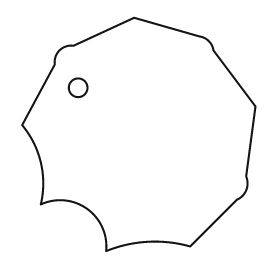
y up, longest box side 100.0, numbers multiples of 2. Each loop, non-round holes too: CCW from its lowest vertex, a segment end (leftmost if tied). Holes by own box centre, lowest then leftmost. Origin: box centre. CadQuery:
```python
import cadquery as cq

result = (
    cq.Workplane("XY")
    .moveTo(-14.0, -50.0)
    .threePointArc((4.0, -46.0), (22.0, -48.0))
    .lineTo(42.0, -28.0)
    .threePointArc((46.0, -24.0), (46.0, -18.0))
    .lineTo(50.0, 12.0)
    .lineTo(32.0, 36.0)
    .threePointArc((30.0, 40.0), (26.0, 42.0))
    .lineTo(-2.0, 50.0)
    .lineTo(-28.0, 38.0)
    .threePointArc((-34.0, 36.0), (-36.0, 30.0))
    .lineTo(-50.0, 4.0)
    .threePointArc((-42.0, -12.0), (-42.0, -30.0))
    .threePointArc((-22.0, -32.0), (-14.0, -50.0))
    .close()
    .moveTo(-26.0, 20.0)
    .circle(4.0)
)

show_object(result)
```